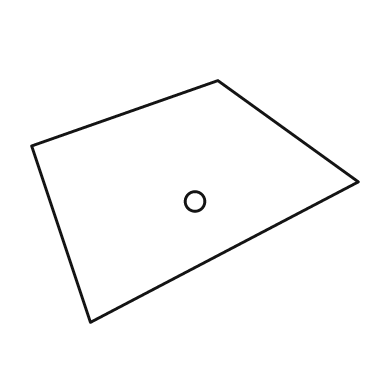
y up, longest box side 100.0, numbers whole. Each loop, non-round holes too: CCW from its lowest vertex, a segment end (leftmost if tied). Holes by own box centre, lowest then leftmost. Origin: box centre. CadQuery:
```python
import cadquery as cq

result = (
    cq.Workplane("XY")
    .moveTo(-32.0, -37.0)
    .lineTo(50.0, 6.0)
    .lineTo(7.0, 37.0)
    .lineTo(-50.0, 17.0)
    .close()
    .moveTo(0.0, 0.0)
    .circle(3.0)
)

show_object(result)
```